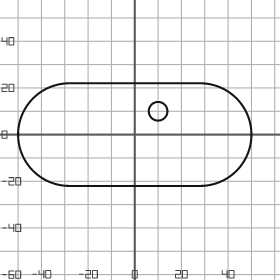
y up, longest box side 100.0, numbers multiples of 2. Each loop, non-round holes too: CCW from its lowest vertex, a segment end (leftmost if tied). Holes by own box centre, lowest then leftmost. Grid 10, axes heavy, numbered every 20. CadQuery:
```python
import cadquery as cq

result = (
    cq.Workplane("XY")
    .moveTo(-28.0, -22.0)
    .lineTo(28.0, -22.0)
    .threePointArc((50.0, 0.0), (28.0, 22.0))
    .lineTo(-28.0, 22.0)
    .threePointArc((-50.0, 0.0), (-28.0, -22.0))
    .close()
    .moveTo(10.0, 10.0)
    .circle(4.0)
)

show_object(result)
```